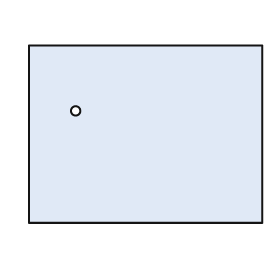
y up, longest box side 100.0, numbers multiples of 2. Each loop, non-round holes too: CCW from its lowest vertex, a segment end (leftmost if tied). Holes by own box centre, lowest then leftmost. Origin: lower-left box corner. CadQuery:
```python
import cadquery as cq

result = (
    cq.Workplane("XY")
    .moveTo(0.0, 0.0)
    .lineTo(100.0, 0.0)
    .lineTo(100.0, 76.0)
    .lineTo(0.0, 76.0)
    .close()
    .moveTo(20.0, 48.0)
    .circle(2.0)
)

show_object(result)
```